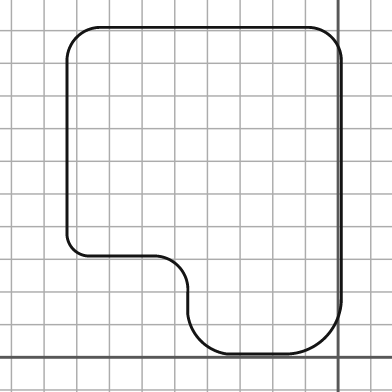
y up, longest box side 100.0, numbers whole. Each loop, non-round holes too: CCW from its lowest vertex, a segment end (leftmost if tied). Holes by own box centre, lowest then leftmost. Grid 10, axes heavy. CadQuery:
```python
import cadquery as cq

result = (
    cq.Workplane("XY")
    .moveTo(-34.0, 1.0)
    .lineTo(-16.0, 1.0)
    .threePointArc((-4.0, 6.0), (1.0, 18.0))
    .lineTo(1.0, 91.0)
    .threePointArc((-2.0, 98.0), (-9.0, 101.0))
    .lineTo(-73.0, 101.0)
    .threePointArc((-80.0, 98.0), (-83.0, 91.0))
    .lineTo(-83.0, 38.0)
    .threePointArc((-81.0, 33.0), (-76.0, 31.0))
    .lineTo(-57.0, 31.0)
    .threePointArc((-49.0, 28.0), (-46.0, 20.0))
    .lineTo(-46.0, 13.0)
    .threePointArc((-42.0, 5.0), (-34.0, 1.0))
    .close()
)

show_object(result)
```